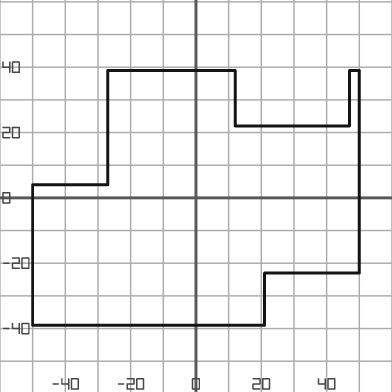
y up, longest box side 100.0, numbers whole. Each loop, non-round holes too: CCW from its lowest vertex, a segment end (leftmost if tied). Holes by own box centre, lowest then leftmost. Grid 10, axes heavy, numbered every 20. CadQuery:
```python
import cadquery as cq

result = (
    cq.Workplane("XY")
    .moveTo(-50.0, -39.0)
    .lineTo(21.0, -39.0)
    .lineTo(21.0, -23.0)
    .lineTo(50.0, -23.0)
    .lineTo(50.0, 39.0)
    .lineTo(47.0, 39.0)
    .lineTo(47.0, 22.0)
    .lineTo(12.0, 22.0)
    .lineTo(12.0, 39.0)
    .lineTo(-27.0, 39.0)
    .lineTo(-27.0, 4.0)
    .lineTo(-50.0, 4.0)
    .close()
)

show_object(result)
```